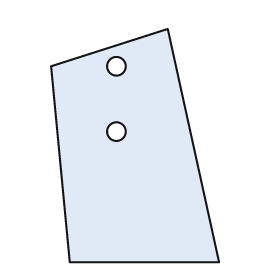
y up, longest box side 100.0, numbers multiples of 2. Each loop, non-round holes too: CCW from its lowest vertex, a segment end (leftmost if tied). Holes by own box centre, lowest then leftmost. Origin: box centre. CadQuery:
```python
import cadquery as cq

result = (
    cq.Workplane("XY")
    .moveTo(-28.0, -50.0)
    .lineTo(36.0, -50.0)
    .lineTo(14.0, 50.0)
    .lineTo(-36.0, 34.0)
    .close()
    .moveTo(-8.0, 6.0)
    .circle(4.0)
    .moveTo(-8.0, 34.0)
    .circle(4.0)
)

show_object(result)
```